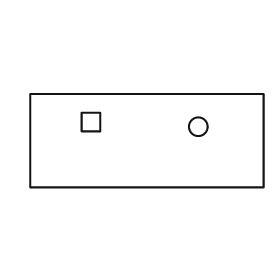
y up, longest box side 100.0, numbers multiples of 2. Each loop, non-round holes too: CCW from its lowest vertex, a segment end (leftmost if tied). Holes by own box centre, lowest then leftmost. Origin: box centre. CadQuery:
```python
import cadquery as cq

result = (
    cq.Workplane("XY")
    .moveTo(-50.0, -20.0)
    .lineTo(50.0, -20.0)
    .lineTo(50.0, 20.0)
    .lineTo(-50.0, 20.0)
    .close()
    .moveTo(22.0, 6.0)
    .circle(4.0)
    .moveTo(-28.0, 4.0)
    .lineTo(-20.0, 4.0)
    .lineTo(-20.0, 12.0)
    .lineTo(-28.0, 12.0)
    .close()
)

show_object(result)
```